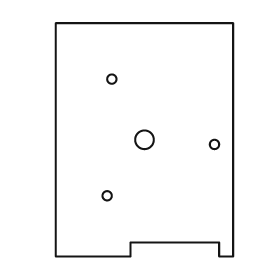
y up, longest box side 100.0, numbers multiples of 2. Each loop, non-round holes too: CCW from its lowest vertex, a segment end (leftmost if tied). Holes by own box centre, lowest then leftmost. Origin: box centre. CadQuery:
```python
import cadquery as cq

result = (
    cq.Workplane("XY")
    .moveTo(-38.0, -50.0)
    .lineTo(-6.0, -50.0)
    .lineTo(-6.0, -44.0)
    .lineTo(32.0, -44.0)
    .lineTo(32.0, -50.0)
    .lineTo(38.0, -50.0)
    .lineTo(38.0, 50.0)
    .lineTo(-38.0, 50.0)
    .close()
    .moveTo(-16.0, -24.0)
    .circle(2.0)
    .moveTo(30.0, -2.0)
    .circle(2.0)
    .moveTo(0.0, 0.0)
    .circle(4.0)
    .moveTo(-14.0, 26.0)
    .circle(2.0)
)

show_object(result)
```